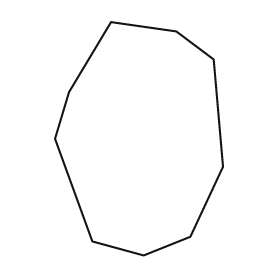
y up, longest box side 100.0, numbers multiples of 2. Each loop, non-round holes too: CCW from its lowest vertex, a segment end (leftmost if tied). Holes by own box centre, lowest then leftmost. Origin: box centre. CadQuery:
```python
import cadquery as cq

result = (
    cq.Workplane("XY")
    .moveTo(2.0, -50.0)
    .lineTo(22.0, -42.0)
    .lineTo(36.0, -12.0)
    .lineTo(32.0, 34.0)
    .lineTo(16.0, 46.0)
    .lineTo(-12.0, 50.0)
    .lineTo(-30.0, 20.0)
    .lineTo(-36.0, 0.0)
    .lineTo(-20.0, -44.0)
    .close()
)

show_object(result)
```